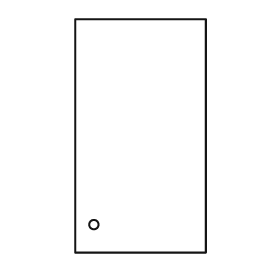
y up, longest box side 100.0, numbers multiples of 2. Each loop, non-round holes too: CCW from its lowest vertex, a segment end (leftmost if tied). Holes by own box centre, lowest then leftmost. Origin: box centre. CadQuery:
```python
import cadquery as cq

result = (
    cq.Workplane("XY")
    .moveTo(-28.0, -50.0)
    .lineTo(28.0, -50.0)
    .lineTo(28.0, 50.0)
    .lineTo(-28.0, 50.0)
    .close()
    .moveTo(-20.0, -38.0)
    .circle(2.0)
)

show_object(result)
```